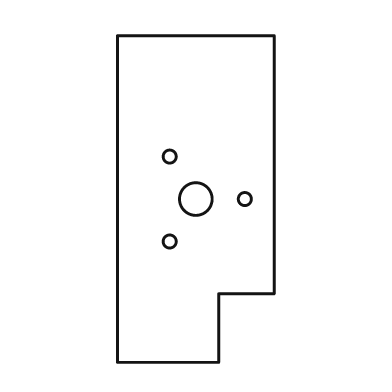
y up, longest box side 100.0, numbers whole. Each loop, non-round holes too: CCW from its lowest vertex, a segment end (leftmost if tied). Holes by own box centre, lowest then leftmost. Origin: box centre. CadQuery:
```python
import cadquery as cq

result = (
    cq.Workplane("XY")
    .moveTo(-24.0, -50.0)
    .lineTo(7.0, -50.0)
    .lineTo(7.0, -29.0)
    .lineTo(24.0, -29.0)
    .lineTo(24.0, 50.0)
    .lineTo(-24.0, 50.0)
    .close()
    .moveTo(-8.0, -13.0)
    .circle(2.0)
    .moveTo(0.0, 0.0)
    .circle(5.0)
    .moveTo(15.0, 0.0)
    .circle(2.0)
    .moveTo(-8.0, 13.0)
    .circle(2.0)
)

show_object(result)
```